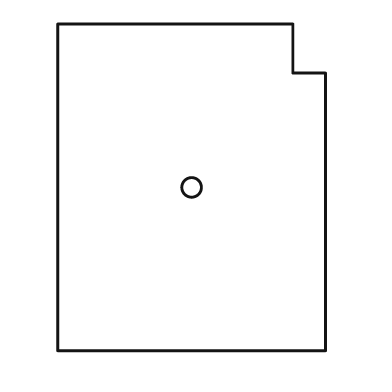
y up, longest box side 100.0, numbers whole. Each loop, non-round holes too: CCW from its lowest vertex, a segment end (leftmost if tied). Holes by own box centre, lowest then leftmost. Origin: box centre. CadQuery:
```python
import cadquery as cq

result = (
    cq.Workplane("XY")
    .moveTo(-41.0, -50.0)
    .lineTo(41.0, -50.0)
    .lineTo(41.0, 35.0)
    .lineTo(31.0, 35.0)
    .lineTo(31.0, 50.0)
    .lineTo(-41.0, 50.0)
    .close()
    .moveTo(0.0, 0.0)
    .circle(3.0)
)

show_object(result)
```